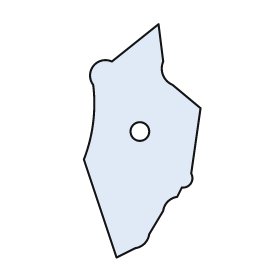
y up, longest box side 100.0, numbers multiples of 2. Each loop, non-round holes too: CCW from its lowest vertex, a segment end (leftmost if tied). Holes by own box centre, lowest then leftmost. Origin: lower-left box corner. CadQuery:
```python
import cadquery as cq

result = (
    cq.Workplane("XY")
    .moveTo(14.0, 0.0)
    .lineTo(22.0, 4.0)
    .threePointArc((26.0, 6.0), (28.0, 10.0))
    .lineTo(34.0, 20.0)
    .threePointArc((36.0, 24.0), (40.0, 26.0))
    .lineTo(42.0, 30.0)
    .threePointArc((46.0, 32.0), (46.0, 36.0))
    .lineTo(50.0, 64.0)
    .lineTo(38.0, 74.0)
    .threePointArc((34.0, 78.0), (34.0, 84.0))
    .lineTo(32.0, 100.0)
    .lineTo(12.0, 84.0)
    .threePointArc((4.0, 82.0), (4.0, 74.0))
    .threePointArc((4.0, 58.0), (0.0, 42.0))
    .close()
    .moveTo(24.0, 54.0)
    .circle(4.0)
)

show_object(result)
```